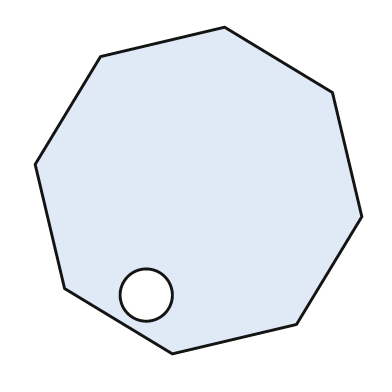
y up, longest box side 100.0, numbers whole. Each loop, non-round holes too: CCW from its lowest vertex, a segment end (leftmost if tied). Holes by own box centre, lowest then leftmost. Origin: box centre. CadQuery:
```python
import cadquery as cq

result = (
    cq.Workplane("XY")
    .moveTo(-8.0, -50.0)
    .lineTo(30.0, -41.0)
    .lineTo(50.0, -8.0)
    .lineTo(41.0, 30.0)
    .lineTo(8.0, 50.0)
    .lineTo(-30.0, 41.0)
    .lineTo(-50.0, 8.0)
    .lineTo(-41.0, -30.0)
    .close()
    .moveTo(-16.0, -32.0)
    .circle(8.0)
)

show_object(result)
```